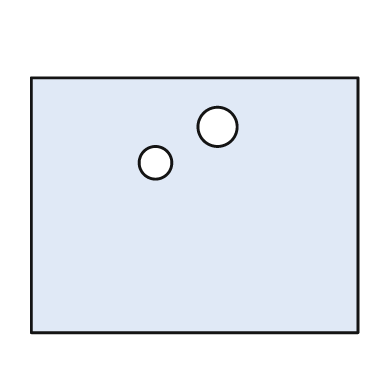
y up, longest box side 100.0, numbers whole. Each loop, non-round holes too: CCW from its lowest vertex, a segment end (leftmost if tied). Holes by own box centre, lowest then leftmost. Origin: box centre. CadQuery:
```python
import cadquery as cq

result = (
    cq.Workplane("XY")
    .moveTo(-50.0, -39.0)
    .lineTo(50.0, -39.0)
    .lineTo(50.0, 39.0)
    .lineTo(-50.0, 39.0)
    .close()
    .moveTo(-12.0, 13.0)
    .circle(5.0)
    .moveTo(7.0, 24.0)
    .circle(6.0)
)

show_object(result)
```